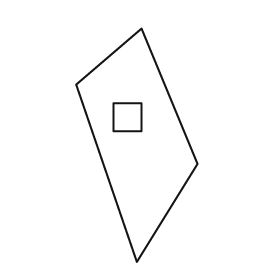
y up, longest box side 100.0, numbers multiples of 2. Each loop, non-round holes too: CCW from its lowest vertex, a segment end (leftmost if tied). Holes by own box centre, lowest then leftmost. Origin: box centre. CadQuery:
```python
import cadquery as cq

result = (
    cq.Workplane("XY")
    .moveTo(0.0, -50.0)
    .lineTo(26.0, -8.0)
    .lineTo(2.0, 50.0)
    .lineTo(-26.0, 26.0)
    .close()
    .moveTo(-10.0, 6.0)
    .lineTo(2.0, 6.0)
    .lineTo(2.0, 18.0)
    .lineTo(-10.0, 18.0)
    .close()
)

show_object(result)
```